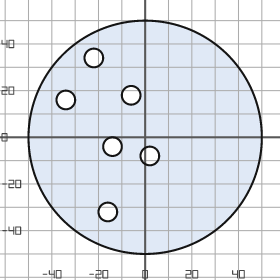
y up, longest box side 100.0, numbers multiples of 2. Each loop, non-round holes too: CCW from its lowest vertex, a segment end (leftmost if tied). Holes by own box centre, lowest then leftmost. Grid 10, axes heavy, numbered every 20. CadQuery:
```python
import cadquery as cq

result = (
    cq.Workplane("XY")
    .moveTo(0.0, 0.0)
    .circle(50.0)
    .moveTo(-16.0, -32.0)
    .circle(4.0)
    .moveTo(2.0, -8.0)
    .circle(4.0)
    .moveTo(-14.0, -4.0)
    .circle(4.0)
    .moveTo(-34.0, 16.0)
    .circle(4.0)
    .moveTo(-6.0, 18.0)
    .circle(4.0)
    .moveTo(-22.0, 34.0)
    .circle(4.0)
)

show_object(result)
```